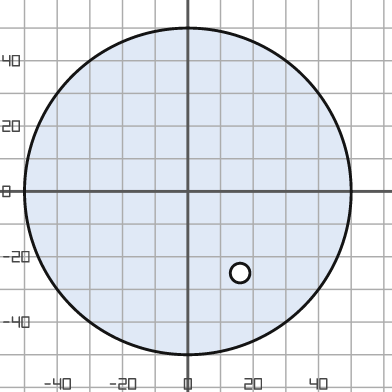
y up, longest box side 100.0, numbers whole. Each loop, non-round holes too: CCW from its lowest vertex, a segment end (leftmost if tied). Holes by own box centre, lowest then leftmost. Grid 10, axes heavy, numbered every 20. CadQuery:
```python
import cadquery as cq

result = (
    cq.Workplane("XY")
    .moveTo(0.0, 0.0)
    .circle(50.0)
    .moveTo(16.0, -25.0)
    .circle(3.0)
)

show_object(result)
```